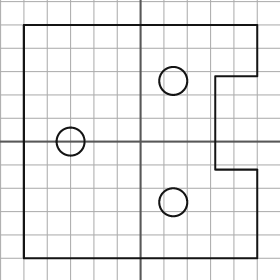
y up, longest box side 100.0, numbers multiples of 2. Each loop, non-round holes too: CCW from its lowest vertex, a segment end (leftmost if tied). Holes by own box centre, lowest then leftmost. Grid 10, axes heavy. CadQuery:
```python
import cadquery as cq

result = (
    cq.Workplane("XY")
    .moveTo(-50.0, -50.0)
    .lineTo(50.0, -50.0)
    .lineTo(50.0, -12.0)
    .lineTo(32.0, -12.0)
    .lineTo(32.0, 28.0)
    .lineTo(50.0, 28.0)
    .lineTo(50.0, 50.0)
    .lineTo(-50.0, 50.0)
    .close()
    .moveTo(14.0, -26.0)
    .circle(6.0)
    .moveTo(-30.0, 0.0)
    .circle(6.0)
    .moveTo(14.0, 26.0)
    .circle(6.0)
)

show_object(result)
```